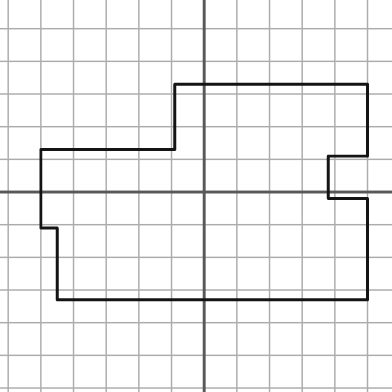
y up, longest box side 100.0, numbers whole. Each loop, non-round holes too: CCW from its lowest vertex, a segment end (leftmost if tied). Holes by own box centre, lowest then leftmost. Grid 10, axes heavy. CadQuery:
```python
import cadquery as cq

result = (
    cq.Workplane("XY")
    .moveTo(-45.0, -33.0)
    .lineTo(50.0, -33.0)
    .lineTo(50.0, -2.0)
    .lineTo(38.0, -2.0)
    .lineTo(38.0, 11.0)
    .lineTo(50.0, 11.0)
    .lineTo(50.0, 33.0)
    .lineTo(-9.0, 33.0)
    .lineTo(-9.0, 13.0)
    .lineTo(-50.0, 13.0)
    .lineTo(-50.0, -11.0)
    .lineTo(-45.0, -11.0)
    .close()
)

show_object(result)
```